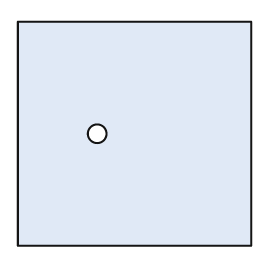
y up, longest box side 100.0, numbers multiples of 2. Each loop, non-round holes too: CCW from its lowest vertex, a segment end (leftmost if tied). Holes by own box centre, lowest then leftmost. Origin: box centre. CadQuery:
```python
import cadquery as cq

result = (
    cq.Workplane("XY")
    .moveTo(-50.0, -48.0)
    .lineTo(50.0, -48.0)
    .lineTo(50.0, 48.0)
    .lineTo(-50.0, 48.0)
    .close()
    .moveTo(-16.0, 0.0)
    .circle(4.0)
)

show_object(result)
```